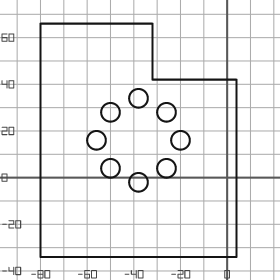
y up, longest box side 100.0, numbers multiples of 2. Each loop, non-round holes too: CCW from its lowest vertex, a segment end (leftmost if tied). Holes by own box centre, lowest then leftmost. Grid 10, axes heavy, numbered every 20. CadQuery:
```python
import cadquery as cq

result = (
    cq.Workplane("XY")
    .moveTo(-80.0, -34.0)
    .lineTo(4.0, -34.0)
    .lineTo(4.0, 42.0)
    .lineTo(-32.0, 42.0)
    .lineTo(-32.0, 66.0)
    .lineTo(-80.0, 66.0)
    .close()
    .moveTo(-38.0, -2.0)
    .circle(4.0)
    .moveTo(-50.0, 4.0)
    .circle(4.0)
    .moveTo(-26.0, 4.0)
    .circle(4.0)
    .moveTo(-56.0, 16.0)
    .circle(4.0)
    .moveTo(-20.0, 16.0)
    .circle(4.0)
    .moveTo(-50.0, 28.0)
    .circle(4.0)
    .moveTo(-26.0, 28.0)
    .circle(4.0)
    .moveTo(-38.0, 34.0)
    .circle(4.0)
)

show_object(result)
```